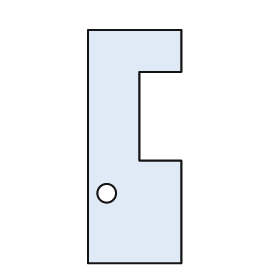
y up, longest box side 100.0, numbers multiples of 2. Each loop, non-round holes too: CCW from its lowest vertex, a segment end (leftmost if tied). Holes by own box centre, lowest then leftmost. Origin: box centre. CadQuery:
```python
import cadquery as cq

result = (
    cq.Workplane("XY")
    .moveTo(-20.0, -50.0)
    .lineTo(20.0, -50.0)
    .lineTo(20.0, -6.0)
    .lineTo(2.0, -6.0)
    .lineTo(2.0, 32.0)
    .lineTo(20.0, 32.0)
    .lineTo(20.0, 50.0)
    .lineTo(-20.0, 50.0)
    .close()
    .moveTo(-12.0, -20.0)
    .circle(4.0)
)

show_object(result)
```